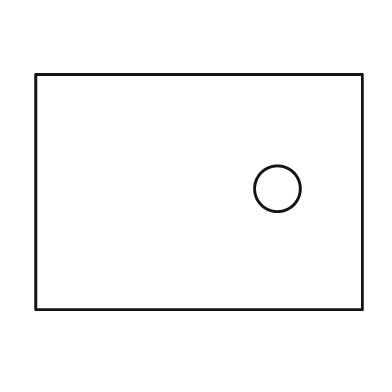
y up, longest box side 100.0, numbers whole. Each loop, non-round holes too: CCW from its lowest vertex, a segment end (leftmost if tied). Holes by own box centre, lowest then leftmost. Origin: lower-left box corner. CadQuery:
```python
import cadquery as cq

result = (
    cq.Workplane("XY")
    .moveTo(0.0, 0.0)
    .lineTo(100.0, 0.0)
    .lineTo(100.0, 72.0)
    .lineTo(0.0, 72.0)
    .close()
    .moveTo(74.0, 37.0)
    .circle(7.0)
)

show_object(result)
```